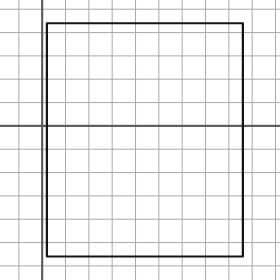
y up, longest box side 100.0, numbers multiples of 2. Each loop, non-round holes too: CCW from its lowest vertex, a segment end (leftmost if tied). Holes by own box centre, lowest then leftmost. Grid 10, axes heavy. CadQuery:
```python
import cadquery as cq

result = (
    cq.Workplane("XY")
    .moveTo(2.0, -56.0)
    .lineTo(86.0, -56.0)
    .lineTo(86.0, 44.0)
    .lineTo(2.0, 44.0)
    .close()
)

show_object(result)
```